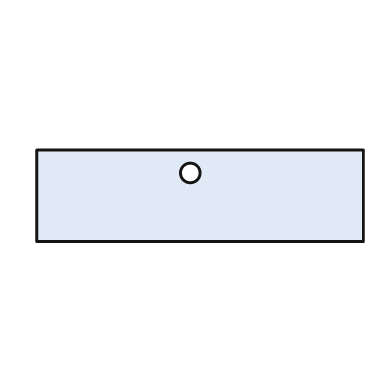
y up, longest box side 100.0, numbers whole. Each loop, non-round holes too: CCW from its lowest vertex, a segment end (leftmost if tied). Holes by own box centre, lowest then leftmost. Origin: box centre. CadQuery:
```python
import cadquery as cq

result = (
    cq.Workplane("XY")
    .moveTo(-50.0, -14.0)
    .lineTo(50.0, -14.0)
    .lineTo(50.0, 14.0)
    .lineTo(-50.0, 14.0)
    .close()
    .moveTo(-3.0, 7.0)
    .circle(3.0)
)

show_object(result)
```